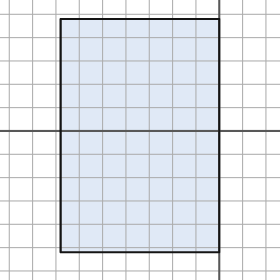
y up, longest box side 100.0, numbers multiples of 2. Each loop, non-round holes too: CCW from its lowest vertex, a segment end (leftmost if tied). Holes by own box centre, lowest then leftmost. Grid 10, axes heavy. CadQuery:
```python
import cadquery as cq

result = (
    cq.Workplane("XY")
    .moveTo(-68.0, -52.0)
    .lineTo(0.0, -52.0)
    .lineTo(0.0, 48.0)
    .lineTo(-68.0, 48.0)
    .close()
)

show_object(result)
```